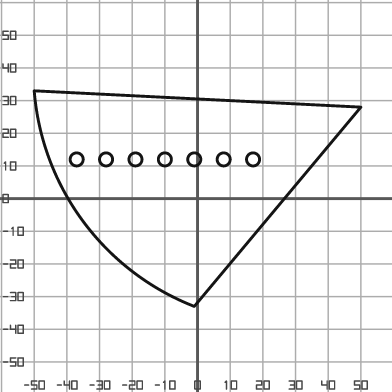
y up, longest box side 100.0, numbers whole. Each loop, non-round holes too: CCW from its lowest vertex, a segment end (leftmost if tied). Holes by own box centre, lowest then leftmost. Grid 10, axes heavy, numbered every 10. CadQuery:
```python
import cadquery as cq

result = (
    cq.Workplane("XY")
    .moveTo(-1.0, -33.0)
    .lineTo(50.0, 28.0)
    .lineTo(-50.0, 33.0)
    .threePointArc((-35.0, -7.0), (-1.0, -33.0))
    .close()
    .moveTo(-37.0, 12.0)
    .circle(2.0)
    .moveTo(-28.0, 12.0)
    .circle(2.0)
    .moveTo(-19.0, 12.0)
    .circle(2.0)
    .moveTo(-10.0, 12.0)
    .circle(2.0)
    .moveTo(-1.0, 12.0)
    .circle(2.0)
    .moveTo(8.0, 12.0)
    .circle(2.0)
    .moveTo(17.0, 12.0)
    .circle(2.0)
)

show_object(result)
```